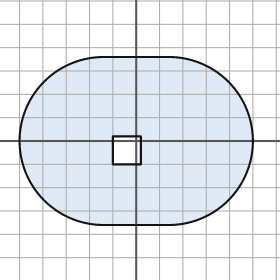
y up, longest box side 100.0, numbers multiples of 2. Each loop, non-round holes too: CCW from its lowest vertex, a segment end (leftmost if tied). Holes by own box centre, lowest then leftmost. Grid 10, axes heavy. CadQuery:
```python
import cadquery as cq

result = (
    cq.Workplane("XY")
    .moveTo(-14.0, -36.0)
    .lineTo(14.0, -36.0)
    .threePointArc((50.0, 0.0), (14.0, 36.0))
    .lineTo(-14.0, 36.0)
    .threePointArc((-50.0, 0.0), (-14.0, -36.0))
    .close()
    .moveTo(-10.0, -10.0)
    .lineTo(2.0, -10.0)
    .lineTo(2.0, 2.0)
    .lineTo(-10.0, 2.0)
    .close()
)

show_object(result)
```